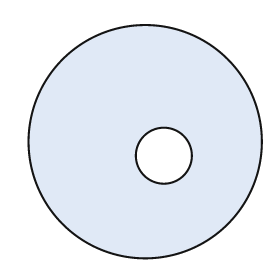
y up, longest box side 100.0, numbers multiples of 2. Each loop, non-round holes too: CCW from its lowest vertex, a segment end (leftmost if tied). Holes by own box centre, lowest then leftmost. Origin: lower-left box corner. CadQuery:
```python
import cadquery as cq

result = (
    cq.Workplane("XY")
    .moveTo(50.0, 50.0)
    .circle(50.0)
    .moveTo(58.0, 44.0)
    .circle(12.0)
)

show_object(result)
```